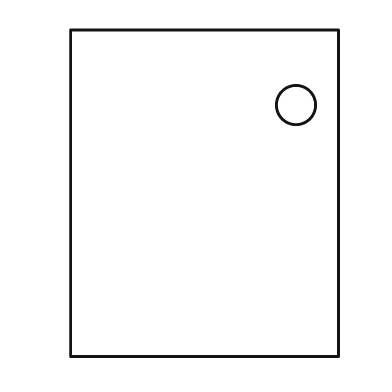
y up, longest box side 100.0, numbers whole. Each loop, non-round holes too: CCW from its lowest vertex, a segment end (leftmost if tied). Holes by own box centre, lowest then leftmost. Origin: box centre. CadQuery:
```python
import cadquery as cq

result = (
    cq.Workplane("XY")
    .moveTo(-41.0, -50.0)
    .lineTo(41.0, -50.0)
    .lineTo(41.0, 50.0)
    .lineTo(-41.0, 50.0)
    .close()
    .moveTo(28.0, 27.0)
    .circle(6.0)
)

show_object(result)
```